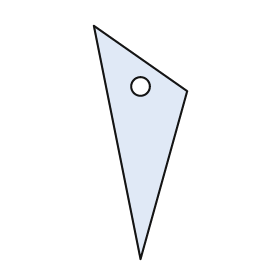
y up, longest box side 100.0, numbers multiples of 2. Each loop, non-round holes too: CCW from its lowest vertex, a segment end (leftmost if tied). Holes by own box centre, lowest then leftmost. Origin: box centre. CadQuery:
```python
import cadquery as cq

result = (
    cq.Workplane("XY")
    .moveTo(0.0, -50.0)
    .lineTo(20.0, 22.0)
    .lineTo(-20.0, 50.0)
    .close()
    .moveTo(0.0, 24.0)
    .circle(4.0)
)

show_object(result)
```